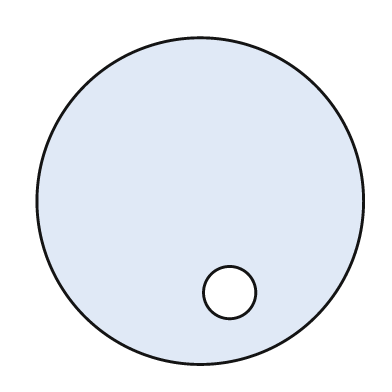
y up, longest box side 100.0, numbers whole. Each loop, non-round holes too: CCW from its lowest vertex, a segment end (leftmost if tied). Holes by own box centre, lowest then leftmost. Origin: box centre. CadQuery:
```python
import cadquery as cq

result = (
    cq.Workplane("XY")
    .moveTo(0.0, 0.0)
    .circle(50.0)
    .moveTo(9.0, -28.0)
    .circle(8.0)
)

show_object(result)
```